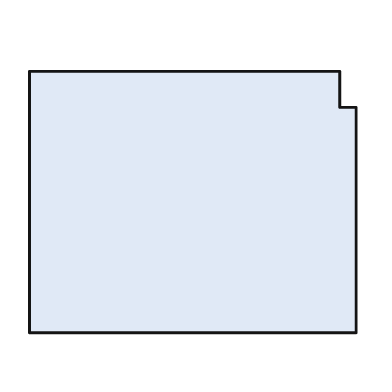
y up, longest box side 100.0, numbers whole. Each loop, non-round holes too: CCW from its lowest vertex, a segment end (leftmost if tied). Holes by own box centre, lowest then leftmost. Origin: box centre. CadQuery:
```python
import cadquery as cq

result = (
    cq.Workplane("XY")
    .moveTo(-50.0, -40.0)
    .lineTo(50.0, -40.0)
    .lineTo(50.0, 29.0)
    .lineTo(45.0, 29.0)
    .lineTo(45.0, 40.0)
    .lineTo(-50.0, 40.0)
    .close()
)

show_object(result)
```